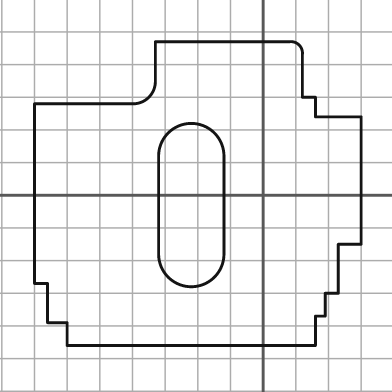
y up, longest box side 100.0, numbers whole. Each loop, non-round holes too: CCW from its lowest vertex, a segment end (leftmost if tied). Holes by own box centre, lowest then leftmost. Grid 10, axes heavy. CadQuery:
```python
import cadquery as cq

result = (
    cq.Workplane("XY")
    .moveTo(-60.0, -46.0)
    .lineTo(16.0, -46.0)
    .lineTo(16.0, -37.0)
    .lineTo(19.0, -37.0)
    .lineTo(19.0, -30.0)
    .lineTo(23.0, -30.0)
    .lineTo(23.0, -15.0)
    .lineTo(30.0, -15.0)
    .lineTo(30.0, 24.0)
    .lineTo(16.0, 24.0)
    .lineTo(16.0, 30.0)
    .lineTo(12.0, 30.0)
    .lineTo(12.0, 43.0)
    .threePointArc((11.0, 46.0), (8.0, 47.0))
    .lineTo(-33.0, 47.0)
    .lineTo(-33.0, 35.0)
    .threePointArc((-35.0, 30.0), (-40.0, 28.0))
    .lineTo(-70.0, 28.0)
    .lineTo(-70.0, -27.0)
    .lineTo(-66.0, -27.0)
    .lineTo(-66.0, -39.0)
    .lineTo(-60.0, -39.0)
    .close()
    .moveTo(-32.0, -18.0)
    .threePointArc((-22.0, -28.0), (-12.0, -18.0))
    .lineTo(-12.0, 12.0)
    .threePointArc((-22.0, 22.0), (-32.0, 12.0))
    .close()
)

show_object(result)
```